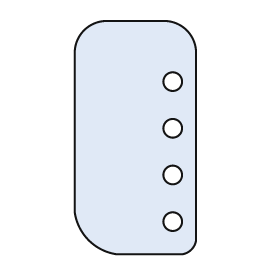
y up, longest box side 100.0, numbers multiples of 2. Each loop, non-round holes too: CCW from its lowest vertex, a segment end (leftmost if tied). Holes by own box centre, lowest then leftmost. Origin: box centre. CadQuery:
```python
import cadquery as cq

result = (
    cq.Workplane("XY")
    .moveTo(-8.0, -50.0)
    .lineTo(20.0, -50.0)
    .threePointArc((24.0, -48.0), (26.0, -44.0))
    .lineTo(26.0, 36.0)
    .threePointArc((22.0, 46.0), (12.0, 50.0))
    .lineTo(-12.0, 50.0)
    .threePointArc((-22.0, 46.0), (-26.0, 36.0))
    .lineTo(-26.0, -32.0)
    .threePointArc((-20.0, -44.0), (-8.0, -50.0))
    .close()
    .moveTo(16.0, -36.0)
    .circle(4.0)
    .moveTo(16.0, -16.0)
    .circle(4.0)
    .moveTo(16.0, 4.0)
    .circle(4.0)
    .moveTo(16.0, 24.0)
    .circle(4.0)
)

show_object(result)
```